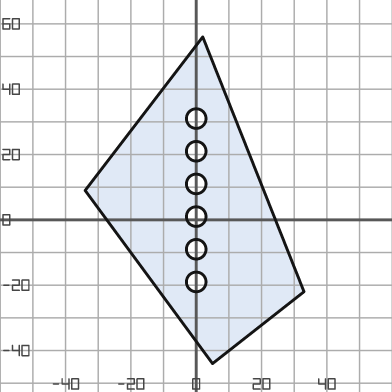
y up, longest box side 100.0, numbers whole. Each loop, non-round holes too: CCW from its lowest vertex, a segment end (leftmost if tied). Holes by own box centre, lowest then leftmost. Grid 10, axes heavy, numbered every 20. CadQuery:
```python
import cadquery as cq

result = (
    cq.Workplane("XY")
    .moveTo(5.0, -44.0)
    .lineTo(33.0, -22.0)
    .lineTo(2.0, 56.0)
    .lineTo(-34.0, 9.0)
    .close()
    .moveTo(0.0, -19.0)
    .circle(3.0)
    .moveTo(0.0, -9.0)
    .circle(3.0)
    .moveTo(0.0, 1.0)
    .circle(3.0)
    .moveTo(0.0, 11.0)
    .circle(3.0)
    .moveTo(0.0, 21.0)
    .circle(3.0)
    .moveTo(0.0, 31.0)
    .circle(3.0)
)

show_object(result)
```